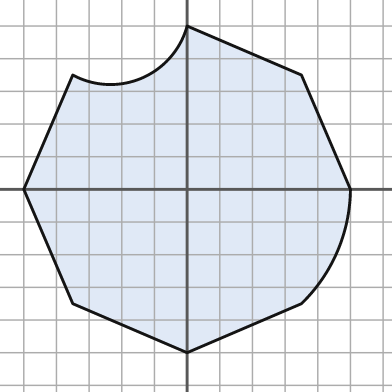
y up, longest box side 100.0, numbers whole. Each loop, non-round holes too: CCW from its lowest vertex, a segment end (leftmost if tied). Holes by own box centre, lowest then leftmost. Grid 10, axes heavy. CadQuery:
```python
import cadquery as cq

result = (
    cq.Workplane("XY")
    .moveTo(0.0, -50.0)
    .lineTo(35.0, -35.0)
    .threePointArc((46.0, -19.0), (50.0, 0.0))
    .lineTo(35.0, 35.0)
    .lineTo(0.0, 50.0)
    .threePointArc((-14.0, 34.0), (-35.0, 35.0))
    .lineTo(-50.0, 0.0)
    .lineTo(-35.0, -35.0)
    .close()
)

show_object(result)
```